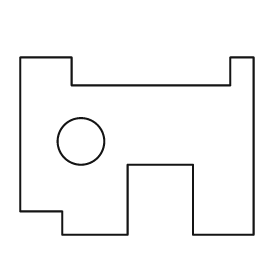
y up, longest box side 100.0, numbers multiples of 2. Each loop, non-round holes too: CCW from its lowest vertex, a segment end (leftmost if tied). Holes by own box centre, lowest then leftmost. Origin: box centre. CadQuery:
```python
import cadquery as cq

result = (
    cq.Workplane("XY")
    .moveTo(-32.0, -38.0)
    .lineTo(-4.0, -38.0)
    .lineTo(-4.0, -8.0)
    .lineTo(24.0, -8.0)
    .lineTo(24.0, -38.0)
    .lineTo(50.0, -38.0)
    .lineTo(50.0, 38.0)
    .lineTo(40.0, 38.0)
    .lineTo(40.0, 26.0)
    .lineTo(-28.0, 26.0)
    .lineTo(-28.0, 38.0)
    .lineTo(-50.0, 38.0)
    .lineTo(-50.0, -28.0)
    .lineTo(-32.0, -28.0)
    .close()
    .moveTo(-24.0, 2.0)
    .circle(10.0)
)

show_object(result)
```